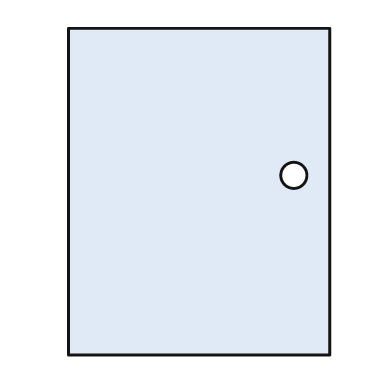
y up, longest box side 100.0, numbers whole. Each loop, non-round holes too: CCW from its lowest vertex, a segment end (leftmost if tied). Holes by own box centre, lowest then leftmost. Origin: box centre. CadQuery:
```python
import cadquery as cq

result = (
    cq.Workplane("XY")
    .moveTo(-40.0, -50.0)
    .lineTo(40.0, -50.0)
    .lineTo(40.0, 50.0)
    .lineTo(-40.0, 50.0)
    .close()
    .moveTo(29.0, 5.0)
    .circle(4.0)
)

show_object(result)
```